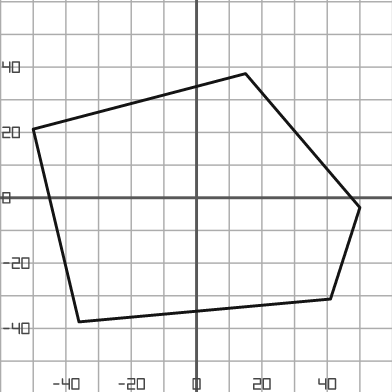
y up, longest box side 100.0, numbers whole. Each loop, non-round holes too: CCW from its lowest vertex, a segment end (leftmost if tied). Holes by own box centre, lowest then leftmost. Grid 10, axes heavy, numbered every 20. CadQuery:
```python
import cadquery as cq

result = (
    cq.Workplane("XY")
    .moveTo(-36.0, -38.0)
    .lineTo(41.0, -31.0)
    .lineTo(50.0, -3.0)
    .lineTo(15.0, 38.0)
    .lineTo(-50.0, 21.0)
    .close()
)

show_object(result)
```